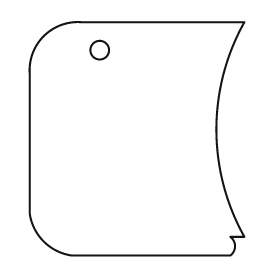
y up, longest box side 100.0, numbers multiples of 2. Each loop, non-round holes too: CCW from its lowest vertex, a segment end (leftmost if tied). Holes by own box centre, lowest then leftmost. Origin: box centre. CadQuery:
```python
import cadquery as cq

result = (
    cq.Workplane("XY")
    .moveTo(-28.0, -50.0)
    .lineTo(40.0, -50.0)
    .threePointArc((42.0, -46.0), (40.0, -42.0))
    .lineTo(46.0, -42.0)
    .threePointArc((34.0, 4.0), (46.0, 50.0))
    .lineTo(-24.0, 50.0)
    .threePointArc((-40.0, 44.0), (-46.0, 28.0))
    .lineTo(-46.0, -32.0)
    .threePointArc((-40.0, -44.0), (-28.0, -50.0))
    .close()
    .moveTo(-16.0, 38.0)
    .circle(4.0)
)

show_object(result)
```